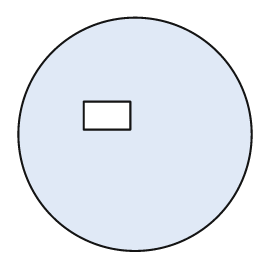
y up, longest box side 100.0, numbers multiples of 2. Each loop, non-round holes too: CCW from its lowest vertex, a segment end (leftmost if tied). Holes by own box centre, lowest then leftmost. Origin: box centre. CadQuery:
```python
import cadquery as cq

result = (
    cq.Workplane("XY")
    .moveTo(0.0, 0.0)
    .circle(50.0)
    .moveTo(-22.0, 2.0)
    .lineTo(-2.0, 2.0)
    .lineTo(-2.0, 14.0)
    .lineTo(-22.0, 14.0)
    .close()
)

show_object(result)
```